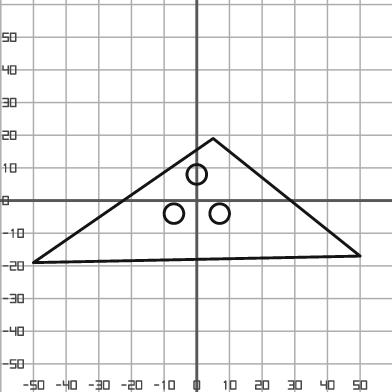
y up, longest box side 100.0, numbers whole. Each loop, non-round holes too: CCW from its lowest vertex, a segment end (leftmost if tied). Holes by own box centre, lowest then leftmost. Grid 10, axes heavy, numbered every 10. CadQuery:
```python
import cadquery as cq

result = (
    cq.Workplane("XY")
    .moveTo(-50.0, -19.0)
    .lineTo(50.0, -17.0)
    .lineTo(5.0, 19.0)
    .close()
    .moveTo(-7.0, -4.0)
    .circle(3.0)
    .moveTo(7.0, -4.0)
    .circle(3.0)
    .moveTo(0.0, 8.0)
    .circle(3.0)
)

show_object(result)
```